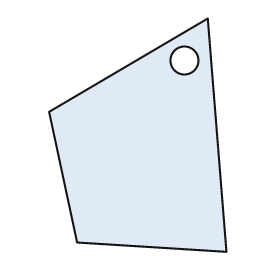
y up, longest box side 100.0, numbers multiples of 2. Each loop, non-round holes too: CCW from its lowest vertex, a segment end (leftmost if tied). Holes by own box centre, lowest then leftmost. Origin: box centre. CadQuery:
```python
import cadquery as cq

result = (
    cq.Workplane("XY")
    .moveTo(38.0, -50.0)
    .lineTo(30.0, 50.0)
    .lineTo(-38.0, 10.0)
    .lineTo(-26.0, -46.0)
    .close()
    .moveTo(20.0, 32.0)
    .circle(6.0)
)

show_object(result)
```